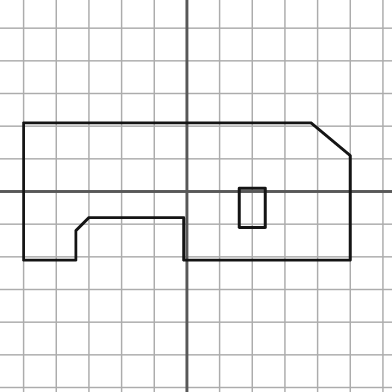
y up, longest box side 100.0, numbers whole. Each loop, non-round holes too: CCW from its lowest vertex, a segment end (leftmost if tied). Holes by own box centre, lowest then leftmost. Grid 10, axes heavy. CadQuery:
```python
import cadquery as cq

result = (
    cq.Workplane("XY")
    .moveTo(-50.0, -21.0)
    .lineTo(-34.0, -21.0)
    .lineTo(-34.0, -12.0)
    .lineTo(-30.0, -8.0)
    .lineTo(-1.0, -8.0)
    .lineTo(-1.0, -21.0)
    .lineTo(50.0, -21.0)
    .lineTo(50.0, 11.0)
    .lineTo(38.0, 21.0)
    .lineTo(-50.0, 21.0)
    .close()
    .moveTo(16.0, -11.0)
    .lineTo(24.0, -11.0)
    .lineTo(24.0, 1.0)
    .lineTo(16.0, 1.0)
    .close()
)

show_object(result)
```